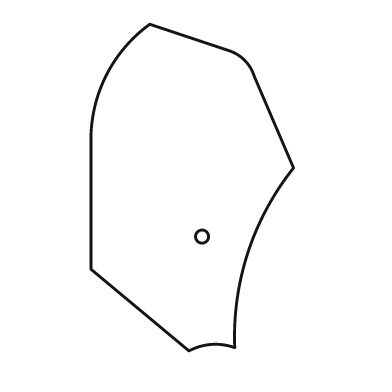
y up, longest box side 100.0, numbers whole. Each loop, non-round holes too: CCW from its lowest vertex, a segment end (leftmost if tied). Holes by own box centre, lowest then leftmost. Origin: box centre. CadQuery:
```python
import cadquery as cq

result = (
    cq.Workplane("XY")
    .moveTo(-1.0, -50.0)
    .threePointArc((6.0, -48.0), (13.0, -49.0))
    .threePointArc((17.0, -20.0), (31.0, 6.0))
    .lineTo(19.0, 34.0)
    .threePointArc((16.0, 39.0), (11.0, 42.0))
    .lineTo(-13.0, 50.0)
    .threePointArc((-26.0, 35.0), (-31.0, 16.0))
    .lineTo(-31.0, -25.0)
    .close()
    .moveTo(3.0, -15.0)
    .circle(2.0)
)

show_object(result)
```